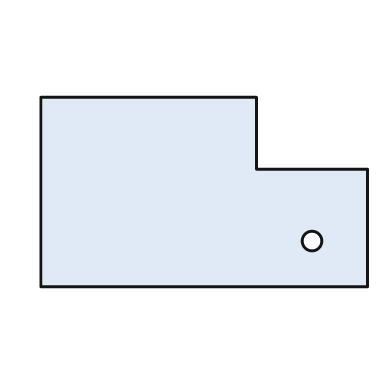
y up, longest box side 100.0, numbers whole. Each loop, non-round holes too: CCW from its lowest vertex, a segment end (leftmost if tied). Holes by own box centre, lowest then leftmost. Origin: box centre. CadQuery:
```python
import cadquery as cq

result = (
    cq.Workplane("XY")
    .moveTo(-50.0, -29.0)
    .lineTo(50.0, -29.0)
    .lineTo(50.0, 7.0)
    .lineTo(16.0, 7.0)
    .lineTo(16.0, 29.0)
    .lineTo(-50.0, 29.0)
    .close()
    .moveTo(33.0, -15.0)
    .circle(3.0)
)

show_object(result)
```